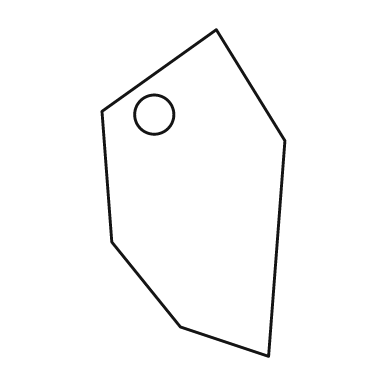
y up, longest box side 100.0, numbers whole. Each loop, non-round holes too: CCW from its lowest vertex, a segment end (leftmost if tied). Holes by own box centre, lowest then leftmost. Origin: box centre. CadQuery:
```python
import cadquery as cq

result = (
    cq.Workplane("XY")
    .moveTo(23.0, -50.0)
    .lineTo(28.0, 16.0)
    .lineTo(7.0, 50.0)
    .lineTo(-28.0, 25.0)
    .lineTo(-25.0, -15.0)
    .lineTo(-4.0, -41.0)
    .close()
    .moveTo(-12.0, 24.0)
    .circle(6.0)
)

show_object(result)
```